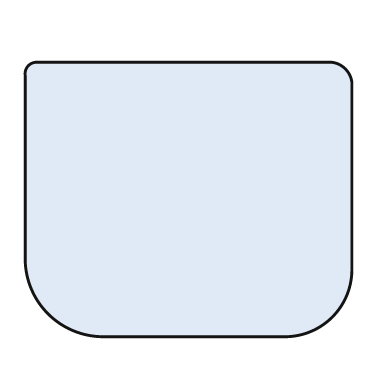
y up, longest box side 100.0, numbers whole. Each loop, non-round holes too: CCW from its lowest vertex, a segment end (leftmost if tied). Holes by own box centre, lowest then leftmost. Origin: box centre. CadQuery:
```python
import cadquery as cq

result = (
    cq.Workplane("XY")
    .moveTo(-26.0, -42.0)
    .lineTo(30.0, -42.0)
    .threePointArc((44.0, -36.0), (50.0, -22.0))
    .lineTo(50.0, 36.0)
    .threePointArc((48.0, 40.0), (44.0, 42.0))
    .lineTo(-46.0, 42.0)
    .threePointArc((-49.0, 41.0), (-50.0, 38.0))
    .lineTo(-50.0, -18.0)
    .threePointArc((-43.0, -35.0), (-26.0, -42.0))
    .close()
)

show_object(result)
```